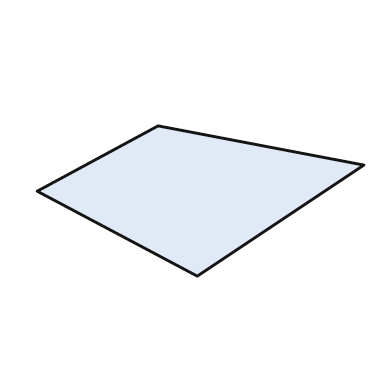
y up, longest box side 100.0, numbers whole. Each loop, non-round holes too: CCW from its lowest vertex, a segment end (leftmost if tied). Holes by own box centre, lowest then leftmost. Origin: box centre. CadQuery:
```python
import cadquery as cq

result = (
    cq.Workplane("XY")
    .moveTo(-1.0, -23.0)
    .lineTo(50.0, 11.0)
    .lineTo(-13.0, 23.0)
    .lineTo(-50.0, 3.0)
    .close()
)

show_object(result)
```